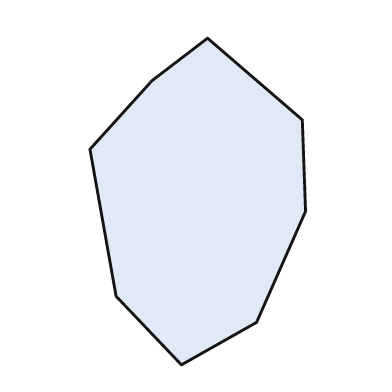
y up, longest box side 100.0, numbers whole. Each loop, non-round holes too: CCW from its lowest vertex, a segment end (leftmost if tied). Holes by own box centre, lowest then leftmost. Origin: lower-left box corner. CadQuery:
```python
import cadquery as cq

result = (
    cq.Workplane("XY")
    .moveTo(28.0, 0.0)
    .lineTo(51.0, 13.0)
    .lineTo(66.0, 47.0)
    .lineTo(65.0, 75.0)
    .lineTo(36.0, 100.0)
    .lineTo(19.0, 87.0)
    .lineTo(0.0, 66.0)
    .lineTo(8.0, 21.0)
    .close()
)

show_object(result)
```